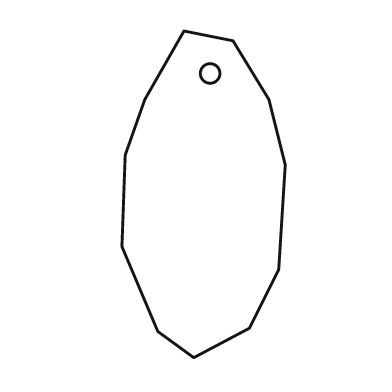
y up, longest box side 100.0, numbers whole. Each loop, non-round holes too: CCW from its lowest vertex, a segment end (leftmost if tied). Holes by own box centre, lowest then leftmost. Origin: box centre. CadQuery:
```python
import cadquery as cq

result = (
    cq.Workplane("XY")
    .moveTo(-3.0, -50.0)
    .lineTo(14.0, -41.0)
    .lineTo(23.0, -23.0)
    .lineTo(25.0, 9.0)
    .lineTo(20.0, 29.0)
    .lineTo(9.0, 47.0)
    .lineTo(-6.0, 50.0)
    .lineTo(-18.0, 29.0)
    .lineTo(-24.0, 12.0)
    .lineTo(-25.0, -16.0)
    .lineTo(-14.0, -42.0)
    .close()
    .moveTo(2.0, 37.0)
    .circle(3.0)
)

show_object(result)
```